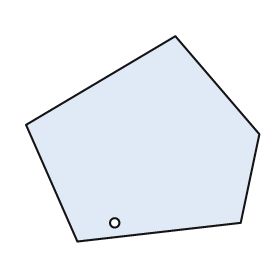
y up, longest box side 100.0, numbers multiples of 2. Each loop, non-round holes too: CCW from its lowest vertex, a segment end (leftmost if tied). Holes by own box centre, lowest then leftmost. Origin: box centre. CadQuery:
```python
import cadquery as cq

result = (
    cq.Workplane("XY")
    .moveTo(-28.0, -44.0)
    .lineTo(42.0, -36.0)
    .lineTo(50.0, 2.0)
    .lineTo(14.0, 44.0)
    .lineTo(-50.0, 6.0)
    .close()
    .moveTo(-12.0, -36.0)
    .circle(2.0)
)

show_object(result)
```